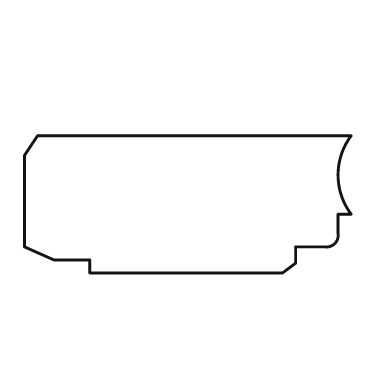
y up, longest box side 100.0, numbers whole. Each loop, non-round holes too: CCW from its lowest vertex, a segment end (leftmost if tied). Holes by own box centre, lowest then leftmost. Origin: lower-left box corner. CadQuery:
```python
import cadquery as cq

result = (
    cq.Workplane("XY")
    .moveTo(20.0, 0.0)
    .lineTo(79.0, 0.0)
    .lineTo(83.0, 3.0)
    .lineTo(83.0, 8.0)
    .lineTo(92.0, 8.0)
    .threePointArc((95.0, 9.0), (96.0, 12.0))
    .lineTo(96.0, 18.0)
    .lineTo(100.0, 18.0)
    .threePointArc((96.0, 30.0), (100.0, 42.0))
    .lineTo(4.0, 42.0)
    .lineTo(0.0, 36.0)
    .lineTo(0.0, 8.0)
    .lineTo(9.0, 4.0)
    .lineTo(20.0, 4.0)
    .close()
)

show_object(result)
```